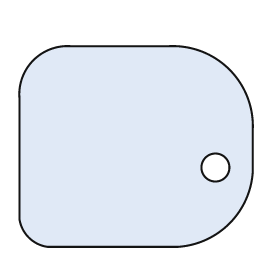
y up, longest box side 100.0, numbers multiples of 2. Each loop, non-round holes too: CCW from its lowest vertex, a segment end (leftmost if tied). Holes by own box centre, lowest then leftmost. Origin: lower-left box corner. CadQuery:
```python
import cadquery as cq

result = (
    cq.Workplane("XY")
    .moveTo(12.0, 0.0)
    .lineTo(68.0, 0.0)
    .threePointArc((90.0, 10.0), (100.0, 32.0))
    .lineTo(100.0, 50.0)
    .threePointArc((90.0, 76.0), (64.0, 86.0))
    .lineTo(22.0, 86.0)
    .threePointArc((6.0, 80.0), (0.0, 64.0))
    .lineTo(0.0, 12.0)
    .threePointArc((4.0, 4.0), (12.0, 0.0))
    .close()
    .moveTo(84.0, 34.0)
    .circle(6.0)
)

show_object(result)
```